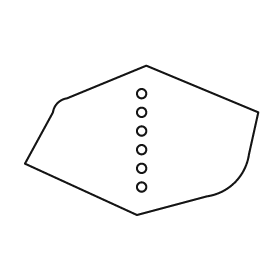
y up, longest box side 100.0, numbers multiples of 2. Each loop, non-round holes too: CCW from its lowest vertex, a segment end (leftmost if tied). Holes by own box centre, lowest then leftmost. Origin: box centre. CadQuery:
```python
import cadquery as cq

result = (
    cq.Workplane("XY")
    .moveTo(-2.0, -32.0)
    .lineTo(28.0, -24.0)
    .threePointArc((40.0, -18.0), (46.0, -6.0))
    .lineTo(50.0, 12.0)
    .lineTo(2.0, 32.0)
    .lineTo(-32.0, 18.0)
    .threePointArc((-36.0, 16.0), (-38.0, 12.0))
    .lineTo(-50.0, -10.0)
    .close()
    .moveTo(0.0, -20.0)
    .circle(2.0)
    .moveTo(0.0, -12.0)
    .circle(2.0)
    .moveTo(0.0, -4.0)
    .circle(2.0)
    .moveTo(0.0, 4.0)
    .circle(2.0)
    .moveTo(0.0, 12.0)
    .circle(2.0)
    .moveTo(0.0, 20.0)
    .circle(2.0)
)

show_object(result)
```